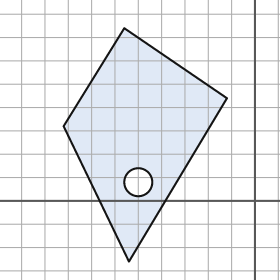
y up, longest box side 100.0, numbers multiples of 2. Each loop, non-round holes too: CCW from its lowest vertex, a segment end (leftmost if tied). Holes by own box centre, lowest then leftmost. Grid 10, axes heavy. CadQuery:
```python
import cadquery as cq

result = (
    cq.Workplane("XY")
    .moveTo(-54.0, -26.0)
    .lineTo(-12.0, 44.0)
    .lineTo(-56.0, 74.0)
    .lineTo(-82.0, 32.0)
    .close()
    .moveTo(-50.0, 8.0)
    .circle(6.0)
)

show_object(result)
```